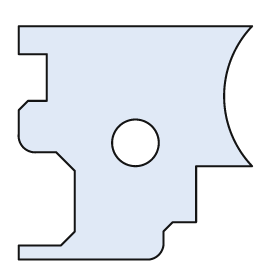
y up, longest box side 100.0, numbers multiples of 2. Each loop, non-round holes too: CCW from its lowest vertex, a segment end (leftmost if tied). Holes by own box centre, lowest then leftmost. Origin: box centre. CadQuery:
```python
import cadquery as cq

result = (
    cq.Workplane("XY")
    .moveTo(-50.0, -50.0)
    .lineTo(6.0, -50.0)
    .threePointArc((10.0, -48.0), (12.0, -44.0))
    .lineTo(12.0, -38.0)
    .lineTo(16.0, -34.0)
    .lineTo(26.0, -34.0)
    .lineTo(26.0, -10.0)
    .lineTo(50.0, -10.0)
    .threePointArc((38.0, 20.0), (50.0, 50.0))
    .lineTo(-50.0, 50.0)
    .lineTo(-50.0, 38.0)
    .lineTo(-38.0, 38.0)
    .lineTo(-38.0, 18.0)
    .lineTo(-46.0, 18.0)
    .lineTo(-50.0, 14.0)
    .lineTo(-50.0, 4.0)
    .threePointArc((-48.0, -2.0), (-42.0, -4.0))
    .lineTo(-34.0, -4.0)
    .lineTo(-26.0, -12.0)
    .lineTo(-26.0, -38.0)
    .lineTo(-32.0, -44.0)
    .lineTo(-50.0, -44.0)
    .close()
    .moveTo(0.0, 0.0)
    .circle(10.0)
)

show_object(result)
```